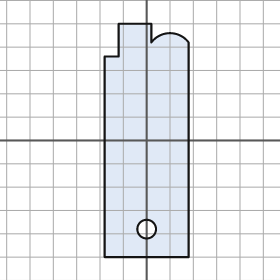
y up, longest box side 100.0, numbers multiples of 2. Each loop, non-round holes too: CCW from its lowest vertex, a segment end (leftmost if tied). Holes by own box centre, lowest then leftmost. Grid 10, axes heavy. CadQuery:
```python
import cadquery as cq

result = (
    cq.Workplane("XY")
    .moveTo(-18.0, -50.0)
    .lineTo(18.0, -50.0)
    .lineTo(18.0, 42.0)
    .threePointArc((10.0, 46.0), (2.0, 42.0))
    .lineTo(2.0, 50.0)
    .lineTo(-12.0, 50.0)
    .lineTo(-12.0, 36.0)
    .lineTo(-18.0, 36.0)
    .close()
    .moveTo(0.0, -38.0)
    .circle(4.0)
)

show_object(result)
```